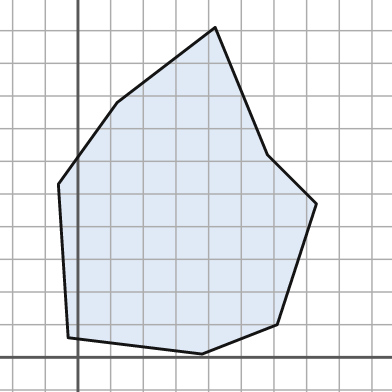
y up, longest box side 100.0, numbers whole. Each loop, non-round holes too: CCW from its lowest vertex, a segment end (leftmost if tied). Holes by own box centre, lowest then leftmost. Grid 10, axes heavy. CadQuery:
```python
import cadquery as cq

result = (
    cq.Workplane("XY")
    .moveTo(38.0, 1.0)
    .lineTo(61.0, 10.0)
    .lineTo(73.0, 47.0)
    .lineTo(58.0, 62.0)
    .lineTo(42.0, 101.0)
    .lineTo(12.0, 78.0)
    .lineTo(-6.0, 53.0)
    .lineTo(-3.0, 6.0)
    .close()
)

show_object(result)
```